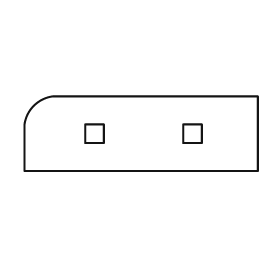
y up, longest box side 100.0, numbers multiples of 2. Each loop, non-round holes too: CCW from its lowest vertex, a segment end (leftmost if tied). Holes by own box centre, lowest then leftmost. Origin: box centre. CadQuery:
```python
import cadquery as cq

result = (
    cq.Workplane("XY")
    .moveTo(-50.0, -16.0)
    .lineTo(50.0, -16.0)
    .lineTo(50.0, 16.0)
    .lineTo(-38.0, 16.0)
    .threePointArc((-46.0, 12.0), (-50.0, 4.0))
    .close()
    .moveTo(-24.0, -4.0)
    .lineTo(-16.0, -4.0)
    .lineTo(-16.0, 4.0)
    .lineTo(-24.0, 4.0)
    .close()
    .moveTo(18.0, -4.0)
    .lineTo(26.0, -4.0)
    .lineTo(26.0, 4.0)
    .lineTo(18.0, 4.0)
    .close()
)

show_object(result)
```